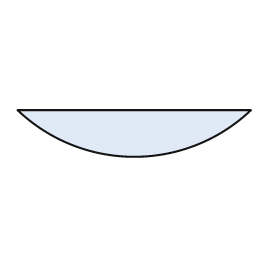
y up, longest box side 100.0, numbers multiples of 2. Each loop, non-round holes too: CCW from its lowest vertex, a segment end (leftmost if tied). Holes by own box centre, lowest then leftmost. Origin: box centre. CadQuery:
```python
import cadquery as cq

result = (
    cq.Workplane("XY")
    .moveTo(-50.0, 10.0)
    .threePointArc((0.0, -10.0), (50.0, 10.0))
    .close()
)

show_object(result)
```